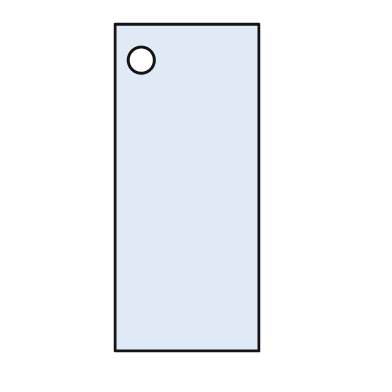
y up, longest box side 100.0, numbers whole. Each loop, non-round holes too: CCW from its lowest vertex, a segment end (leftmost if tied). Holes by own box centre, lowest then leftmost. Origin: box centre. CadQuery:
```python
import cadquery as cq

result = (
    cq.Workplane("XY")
    .moveTo(-22.0, -50.0)
    .lineTo(22.0, -50.0)
    .lineTo(22.0, 50.0)
    .lineTo(-22.0, 50.0)
    .close()
    .moveTo(-14.0, 39.0)
    .circle(4.0)
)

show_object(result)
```